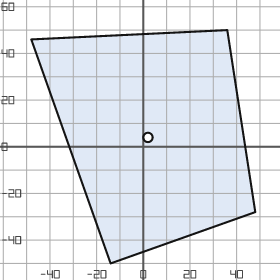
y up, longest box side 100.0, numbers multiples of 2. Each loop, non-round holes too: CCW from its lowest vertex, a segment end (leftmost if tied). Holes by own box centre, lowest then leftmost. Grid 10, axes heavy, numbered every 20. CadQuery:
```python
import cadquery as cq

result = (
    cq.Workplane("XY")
    .moveTo(-14.0, -50.0)
    .lineTo(48.0, -28.0)
    .lineTo(36.0, 50.0)
    .lineTo(-48.0, 46.0)
    .close()
    .moveTo(2.0, 4.0)
    .circle(2.0)
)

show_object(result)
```